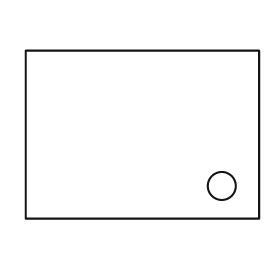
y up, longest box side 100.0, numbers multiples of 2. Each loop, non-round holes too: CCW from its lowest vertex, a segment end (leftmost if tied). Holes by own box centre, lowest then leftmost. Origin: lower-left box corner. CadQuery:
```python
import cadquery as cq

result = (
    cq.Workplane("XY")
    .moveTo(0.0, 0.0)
    .lineTo(100.0, 0.0)
    .lineTo(100.0, 72.0)
    .lineTo(0.0, 72.0)
    .close()
    .moveTo(84.0, 14.0)
    .circle(6.0)
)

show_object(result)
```